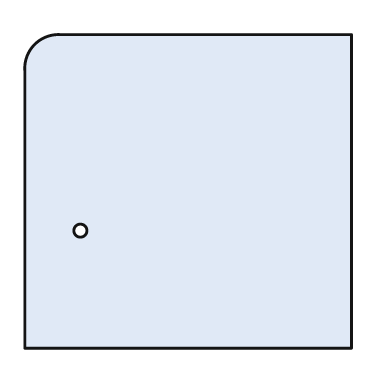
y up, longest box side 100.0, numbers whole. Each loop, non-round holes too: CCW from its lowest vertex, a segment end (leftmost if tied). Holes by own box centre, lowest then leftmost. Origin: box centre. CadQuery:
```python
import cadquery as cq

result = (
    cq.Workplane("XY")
    .moveTo(-50.0, -48.0)
    .lineTo(50.0, -48.0)
    .lineTo(50.0, 48.0)
    .lineTo(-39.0, 48.0)
    .threePointArc((-47.0, 45.0), (-50.0, 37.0))
    .close()
    .moveTo(-33.0, -12.0)
    .circle(2.0)
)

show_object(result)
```